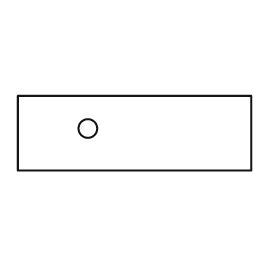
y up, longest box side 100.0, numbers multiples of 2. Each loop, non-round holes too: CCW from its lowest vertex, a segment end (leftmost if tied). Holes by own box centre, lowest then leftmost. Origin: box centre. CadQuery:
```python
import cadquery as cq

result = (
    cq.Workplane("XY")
    .moveTo(-50.0, -16.0)
    .lineTo(50.0, -16.0)
    .lineTo(50.0, 16.0)
    .lineTo(-50.0, 16.0)
    .close()
    .moveTo(-20.0, 2.0)
    .circle(4.0)
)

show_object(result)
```